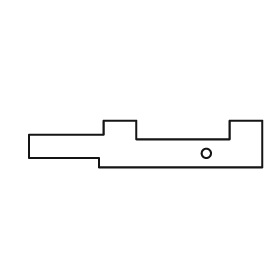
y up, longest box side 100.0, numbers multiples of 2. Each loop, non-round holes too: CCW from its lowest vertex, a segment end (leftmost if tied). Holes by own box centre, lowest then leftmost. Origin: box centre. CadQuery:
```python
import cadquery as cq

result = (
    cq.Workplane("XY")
    .moveTo(-20.0, -10.0)
    .lineTo(50.0, -10.0)
    .lineTo(50.0, 10.0)
    .lineTo(36.0, 10.0)
    .lineTo(36.0, 2.0)
    .lineTo(-4.0, 2.0)
    .lineTo(-4.0, 10.0)
    .lineTo(-18.0, 10.0)
    .lineTo(-18.0, 4.0)
    .lineTo(-50.0, 4.0)
    .lineTo(-50.0, -6.0)
    .lineTo(-20.0, -6.0)
    .close()
    .moveTo(26.0, -4.0)
    .circle(2.0)
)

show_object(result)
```